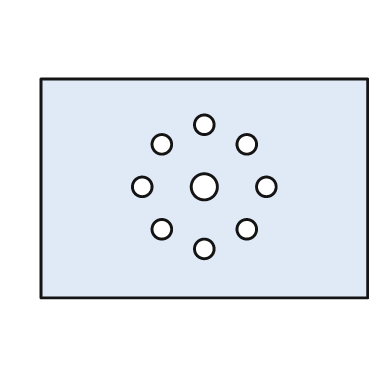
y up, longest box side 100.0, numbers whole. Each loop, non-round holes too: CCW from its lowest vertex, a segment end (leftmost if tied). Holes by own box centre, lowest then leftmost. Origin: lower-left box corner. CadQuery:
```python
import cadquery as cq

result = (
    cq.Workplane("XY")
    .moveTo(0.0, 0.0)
    .lineTo(100.0, 0.0)
    .lineTo(100.0, 67.0)
    .lineTo(0.0, 67.0)
    .close()
    .moveTo(50.0, 15.0)
    .circle(3.0)
    .moveTo(37.0, 21.0)
    .circle(3.0)
    .moveTo(63.0, 21.0)
    .circle(3.0)
    .moveTo(31.0, 34.0)
    .circle(3.0)
    .moveTo(50.0, 34.0)
    .circle(4.0)
    .moveTo(69.0, 34.0)
    .circle(3.0)
    .moveTo(37.0, 47.0)
    .circle(3.0)
    .moveTo(63.0, 47.0)
    .circle(3.0)
    .moveTo(50.0, 53.0)
    .circle(3.0)
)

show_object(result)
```